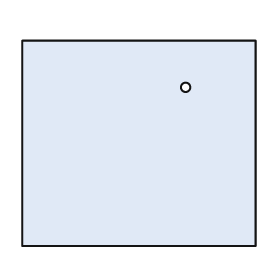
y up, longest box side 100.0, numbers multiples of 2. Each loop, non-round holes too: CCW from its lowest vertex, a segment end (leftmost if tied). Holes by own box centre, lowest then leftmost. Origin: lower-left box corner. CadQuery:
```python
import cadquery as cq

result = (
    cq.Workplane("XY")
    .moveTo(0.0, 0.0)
    .lineTo(100.0, 0.0)
    .lineTo(100.0, 88.0)
    .lineTo(0.0, 88.0)
    .close()
    .moveTo(70.0, 68.0)
    .circle(2.0)
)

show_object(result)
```